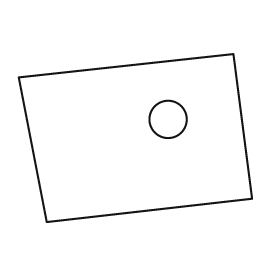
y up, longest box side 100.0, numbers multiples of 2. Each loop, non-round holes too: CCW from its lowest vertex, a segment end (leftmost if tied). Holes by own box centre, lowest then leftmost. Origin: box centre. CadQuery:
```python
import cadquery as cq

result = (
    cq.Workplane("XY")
    .moveTo(-38.0, -36.0)
    .lineTo(50.0, -26.0)
    .lineTo(42.0, 36.0)
    .lineTo(-50.0, 26.0)
    .close()
    .moveTo(14.0, 8.0)
    .circle(8.0)
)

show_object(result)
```